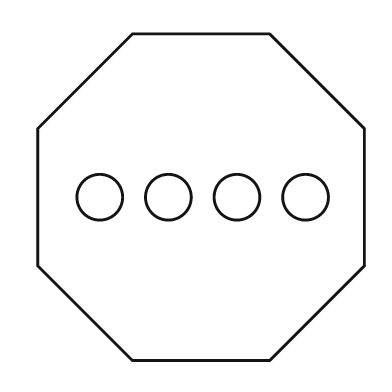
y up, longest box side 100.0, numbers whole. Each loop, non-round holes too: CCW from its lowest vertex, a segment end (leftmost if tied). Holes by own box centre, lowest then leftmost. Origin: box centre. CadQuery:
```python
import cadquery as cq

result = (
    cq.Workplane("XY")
    .moveTo(-21.0, -50.0)
    .lineTo(21.0, -50.0)
    .lineTo(50.0, -21.0)
    .lineTo(50.0, 21.0)
    .lineTo(21.0, 50.0)
    .lineTo(-21.0, 50.0)
    .lineTo(-50.0, 21.0)
    .lineTo(-50.0, -21.0)
    .close()
    .moveTo(-31.0, 0.0)
    .circle(7.0)
    .moveTo(-10.0, 0.0)
    .circle(7.0)
    .moveTo(11.0, 0.0)
    .circle(7.0)
    .moveTo(32.0, 0.0)
    .circle(7.0)
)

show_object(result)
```